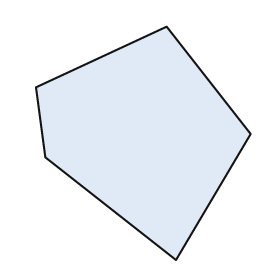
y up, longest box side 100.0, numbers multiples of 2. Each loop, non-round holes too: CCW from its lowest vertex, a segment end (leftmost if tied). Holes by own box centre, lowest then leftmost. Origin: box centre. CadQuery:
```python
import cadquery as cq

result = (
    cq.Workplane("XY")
    .moveTo(14.0, -50.0)
    .lineTo(46.0, 4.0)
    .lineTo(10.0, 50.0)
    .lineTo(-46.0, 24.0)
    .lineTo(-42.0, -6.0)
    .close()
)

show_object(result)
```